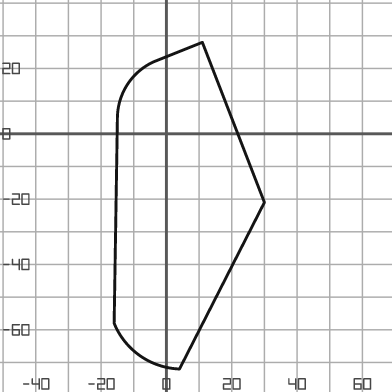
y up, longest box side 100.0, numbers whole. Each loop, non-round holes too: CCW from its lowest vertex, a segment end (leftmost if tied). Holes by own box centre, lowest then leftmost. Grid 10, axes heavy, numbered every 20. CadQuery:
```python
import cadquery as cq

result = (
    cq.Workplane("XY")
    .moveTo(4.0, -72.0)
    .lineTo(30.0, -21.0)
    .lineTo(11.0, 28.0)
    .lineTo(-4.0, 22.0)
    .threePointArc((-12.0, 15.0), (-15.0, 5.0))
    .lineTo(-16.0, -58.0)
    .threePointArc((-8.0, -68.0), (4.0, -72.0))
    .close()
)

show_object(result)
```